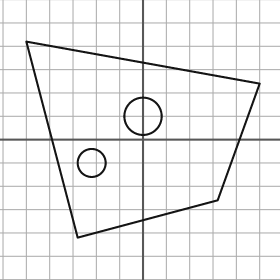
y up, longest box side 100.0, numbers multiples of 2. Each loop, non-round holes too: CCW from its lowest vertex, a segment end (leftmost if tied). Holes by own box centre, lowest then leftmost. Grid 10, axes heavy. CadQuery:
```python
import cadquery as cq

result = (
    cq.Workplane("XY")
    .moveTo(-28.0, -42.0)
    .lineTo(32.0, -26.0)
    .lineTo(50.0, 24.0)
    .lineTo(-50.0, 42.0)
    .close()
    .moveTo(-22.0, -10.0)
    .circle(6.0)
    .moveTo(0.0, 10.0)
    .circle(8.0)
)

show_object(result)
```